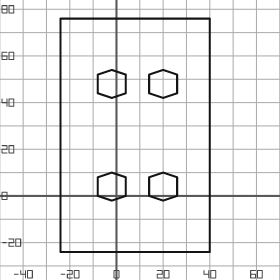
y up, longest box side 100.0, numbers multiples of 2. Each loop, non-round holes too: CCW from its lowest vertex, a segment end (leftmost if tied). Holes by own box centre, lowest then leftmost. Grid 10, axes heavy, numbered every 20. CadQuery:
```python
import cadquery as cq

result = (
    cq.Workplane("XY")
    .moveTo(-24.0, -24.0)
    .lineTo(40.0, -24.0)
    .lineTo(40.0, 76.0)
    .lineTo(-24.0, 76.0)
    .close()
    .moveTo(-2.0, -2.0)
    .lineTo(4.0, 0.0)
    .lineTo(4.0, 8.0)
    .lineTo(-2.0, 10.0)
    .lineTo(-8.0, 8.0)
    .lineTo(-8.0, 0.0)
    .close()
    .moveTo(20.0, -2.0)
    .lineTo(26.0, 0.0)
    .lineTo(26.0, 8.0)
    .lineTo(20.0, 10.0)
    .lineTo(14.0, 8.0)
    .lineTo(14.0, 0.0)
    .close()
    .moveTo(-2.0, 42.0)
    .lineTo(4.0, 44.0)
    .lineTo(4.0, 52.0)
    .lineTo(-2.0, 54.0)
    .lineTo(-8.0, 52.0)
    .lineTo(-8.0, 44.0)
    .close()
    .moveTo(20.0, 42.0)
    .lineTo(26.0, 44.0)
    .lineTo(26.0, 52.0)
    .lineTo(20.0, 54.0)
    .lineTo(14.0, 52.0)
    .lineTo(14.0, 44.0)
    .close()
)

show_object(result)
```